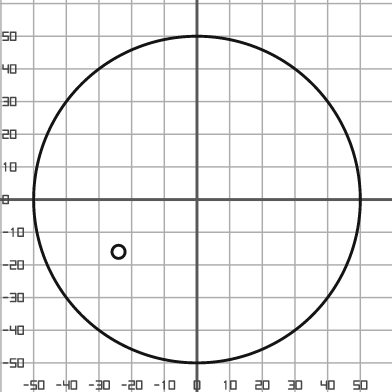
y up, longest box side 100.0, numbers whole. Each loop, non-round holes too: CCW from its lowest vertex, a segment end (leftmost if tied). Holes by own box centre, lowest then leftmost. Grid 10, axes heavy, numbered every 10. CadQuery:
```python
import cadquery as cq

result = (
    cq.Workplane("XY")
    .moveTo(0.0, 0.0)
    .circle(50.0)
    .moveTo(-24.0, -16.0)
    .circle(2.0)
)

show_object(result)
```